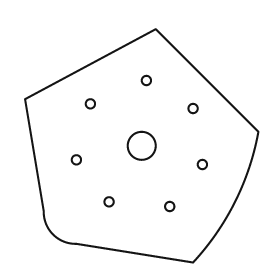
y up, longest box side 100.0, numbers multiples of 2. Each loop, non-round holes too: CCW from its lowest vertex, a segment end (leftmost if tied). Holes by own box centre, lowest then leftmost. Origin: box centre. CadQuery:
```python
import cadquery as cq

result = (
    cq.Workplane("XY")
    .moveTo(22.0, -50.0)
    .threePointArc((40.0, -24.0), (50.0, 6.0))
    .lineTo(6.0, 50.0)
    .lineTo(-50.0, 20.0)
    .lineTo(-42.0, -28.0)
    .threePointArc((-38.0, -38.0), (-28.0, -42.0))
    .close()
    .moveTo(12.0, -26.0)
    .circle(2.0)
    .moveTo(-14.0, -24.0)
    .circle(2.0)
    .moveTo(26.0, -8.0)
    .circle(2.0)
    .moveTo(-28.0, -6.0)
    .circle(2.0)
    .moveTo(0.0, 0.0)
    .circle(6.0)
    .moveTo(22.0, 16.0)
    .circle(2.0)
    .moveTo(-22.0, 18.0)
    .circle(2.0)
    .moveTo(2.0, 28.0)
    .circle(2.0)
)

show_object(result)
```